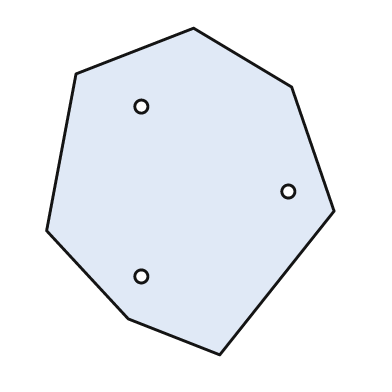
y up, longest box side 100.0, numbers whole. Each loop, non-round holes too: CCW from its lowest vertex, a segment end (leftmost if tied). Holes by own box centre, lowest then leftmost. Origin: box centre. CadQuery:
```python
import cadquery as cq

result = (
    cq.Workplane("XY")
    .moveTo(9.0, -50.0)
    .lineTo(44.0, -6.0)
    .lineTo(31.0, 32.0)
    .lineTo(1.0, 50.0)
    .lineTo(-35.0, 36.0)
    .lineTo(-44.0, -12.0)
    .lineTo(-19.0, -39.0)
    .close()
    .moveTo(-15.0, -26.0)
    .circle(2.0)
    .moveTo(30.0, 0.0)
    .circle(2.0)
    .moveTo(-15.0, 26.0)
    .circle(2.0)
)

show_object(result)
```